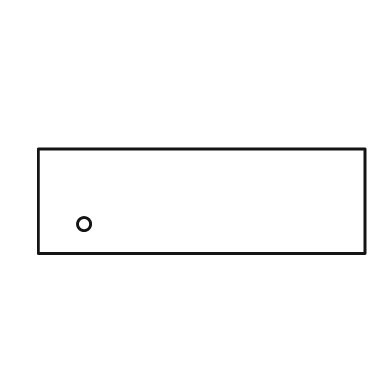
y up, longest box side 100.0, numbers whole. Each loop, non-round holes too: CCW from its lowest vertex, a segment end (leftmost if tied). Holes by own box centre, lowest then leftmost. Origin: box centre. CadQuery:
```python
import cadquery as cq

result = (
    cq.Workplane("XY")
    .moveTo(-50.0, -16.0)
    .lineTo(50.0, -16.0)
    .lineTo(50.0, 16.0)
    .lineTo(-50.0, 16.0)
    .close()
    .moveTo(-36.0, -7.0)
    .circle(2.0)
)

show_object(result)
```